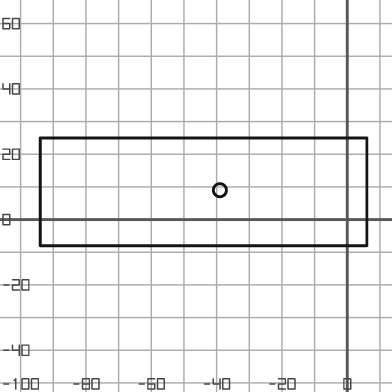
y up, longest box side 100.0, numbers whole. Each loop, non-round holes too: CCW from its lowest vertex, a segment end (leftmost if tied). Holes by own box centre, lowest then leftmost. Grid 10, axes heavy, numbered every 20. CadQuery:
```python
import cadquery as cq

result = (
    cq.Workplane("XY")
    .moveTo(-94.0, -8.0)
    .lineTo(6.0, -8.0)
    .lineTo(6.0, 25.0)
    .lineTo(-94.0, 25.0)
    .close()
    .moveTo(-39.0, 9.0)
    .circle(2.0)
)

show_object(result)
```